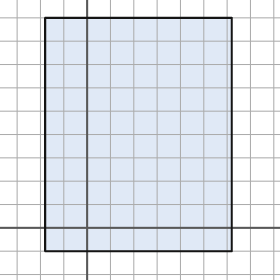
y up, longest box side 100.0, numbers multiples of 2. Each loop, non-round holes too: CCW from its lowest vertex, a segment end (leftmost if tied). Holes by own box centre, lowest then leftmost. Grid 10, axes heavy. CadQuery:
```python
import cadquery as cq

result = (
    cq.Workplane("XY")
    .moveTo(-18.0, -10.0)
    .lineTo(62.0, -10.0)
    .lineTo(62.0, 90.0)
    .lineTo(-18.0, 90.0)
    .close()
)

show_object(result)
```